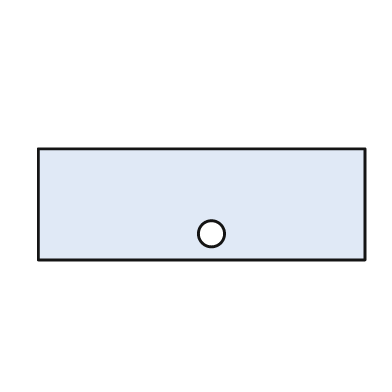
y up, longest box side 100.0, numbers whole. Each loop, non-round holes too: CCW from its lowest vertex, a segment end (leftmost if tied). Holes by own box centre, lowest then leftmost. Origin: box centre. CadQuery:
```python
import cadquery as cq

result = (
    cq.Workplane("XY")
    .moveTo(-50.0, -17.0)
    .lineTo(50.0, -17.0)
    .lineTo(50.0, 17.0)
    .lineTo(-50.0, 17.0)
    .close()
    .moveTo(3.0, -9.0)
    .circle(4.0)
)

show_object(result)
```